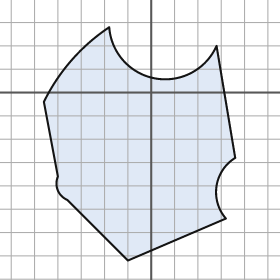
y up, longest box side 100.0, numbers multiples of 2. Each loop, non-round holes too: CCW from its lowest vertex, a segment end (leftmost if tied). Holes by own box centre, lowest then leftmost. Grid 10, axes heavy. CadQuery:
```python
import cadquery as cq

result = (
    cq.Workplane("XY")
    .moveTo(-10.0, -72.0)
    .lineTo(32.0, -54.0)
    .threePointArc((28.0, -40.0), (36.0, -28.0))
    .lineTo(28.0, 20.0)
    .threePointArc((2.0, 6.0), (-18.0, 28.0))
    .threePointArc((-34.0, 14.0), (-46.0, -4.0))
    .lineTo(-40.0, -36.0)
    .threePointArc((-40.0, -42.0), (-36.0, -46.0))
    .close()
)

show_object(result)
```